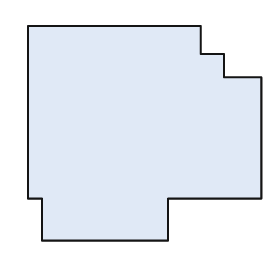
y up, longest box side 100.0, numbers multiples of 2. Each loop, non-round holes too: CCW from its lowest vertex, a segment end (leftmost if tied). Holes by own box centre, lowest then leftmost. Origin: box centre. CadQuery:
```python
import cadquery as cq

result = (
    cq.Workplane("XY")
    .moveTo(-44.0, -46.0)
    .lineTo(10.0, -46.0)
    .lineTo(10.0, -28.0)
    .lineTo(50.0, -28.0)
    .lineTo(50.0, 24.0)
    .lineTo(34.0, 24.0)
    .lineTo(34.0, 34.0)
    .lineTo(24.0, 34.0)
    .lineTo(24.0, 46.0)
    .lineTo(-50.0, 46.0)
    .lineTo(-50.0, -28.0)
    .lineTo(-44.0, -28.0)
    .close()
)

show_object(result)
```